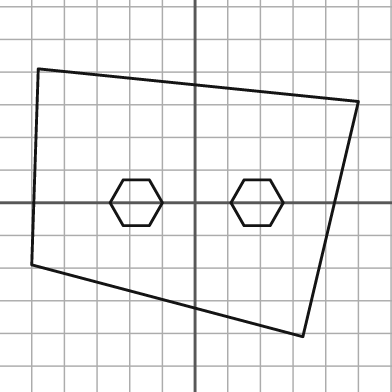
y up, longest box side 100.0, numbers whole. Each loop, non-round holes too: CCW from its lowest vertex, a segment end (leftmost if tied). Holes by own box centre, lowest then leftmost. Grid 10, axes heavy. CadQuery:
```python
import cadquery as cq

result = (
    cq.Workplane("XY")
    .moveTo(33.0, -41.0)
    .lineTo(50.0, 31.0)
    .lineTo(-48.0, 41.0)
    .lineTo(-50.0, -19.0)
    .close()
    .moveTo(-22.0, -7.0)
    .lineTo(-14.0, -7.0)
    .lineTo(-10.0, 0.0)
    .lineTo(-14.0, 7.0)
    .lineTo(-22.0, 7.0)
    .lineTo(-26.0, 0.0)
    .close()
    .moveTo(15.0, -7.0)
    .lineTo(23.0, -7.0)
    .lineTo(27.0, 0.0)
    .lineTo(23.0, 7.0)
    .lineTo(15.0, 7.0)
    .lineTo(11.0, 0.0)
    .close()
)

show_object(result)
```